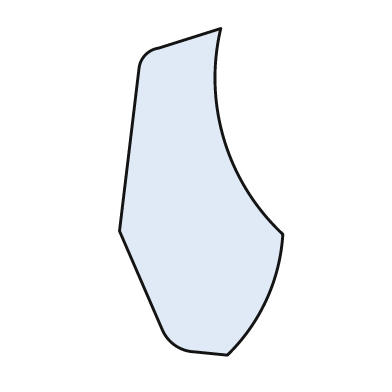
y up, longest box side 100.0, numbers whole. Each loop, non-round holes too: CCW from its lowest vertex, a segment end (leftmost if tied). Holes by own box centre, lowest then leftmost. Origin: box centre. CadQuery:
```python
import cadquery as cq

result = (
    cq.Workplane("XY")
    .moveTo(8.0, -50.0)
    .threePointArc((20.0, -33.0), (25.0, -13.0))
    .threePointArc((7.0, 16.0), (6.0, 50.0))
    .lineTo(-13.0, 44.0)
    .threePointArc((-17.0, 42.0), (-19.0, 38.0))
    .lineTo(-25.0, -12.0)
    .lineTo(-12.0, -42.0)
    .threePointArc((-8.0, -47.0), (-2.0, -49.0))
    .close()
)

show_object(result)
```